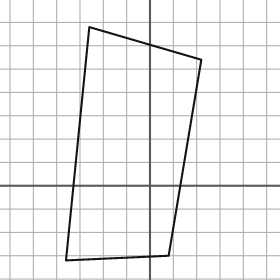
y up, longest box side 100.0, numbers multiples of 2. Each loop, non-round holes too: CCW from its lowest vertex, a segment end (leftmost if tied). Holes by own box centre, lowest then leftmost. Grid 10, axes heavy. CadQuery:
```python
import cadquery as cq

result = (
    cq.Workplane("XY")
    .moveTo(-36.0, -32.0)
    .lineTo(8.0, -30.0)
    .lineTo(22.0, 54.0)
    .lineTo(-26.0, 68.0)
    .close()
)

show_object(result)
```